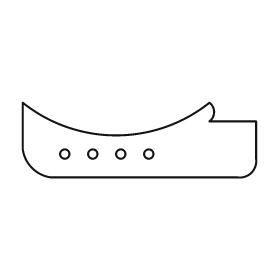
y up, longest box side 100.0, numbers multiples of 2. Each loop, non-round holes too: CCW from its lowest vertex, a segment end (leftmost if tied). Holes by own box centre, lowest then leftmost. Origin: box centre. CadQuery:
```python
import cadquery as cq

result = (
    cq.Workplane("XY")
    .moveTo(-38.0, -16.0)
    .lineTo(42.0, -16.0)
    .threePointArc((48.0, -14.0), (50.0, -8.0))
    .lineTo(50.0, 8.0)
    .lineTo(30.0, 8.0)
    .threePointArc((32.0, 12.0), (30.0, 16.0))
    .threePointArc((-10.0, 2.0), (-50.0, 16.0))
    .lineTo(-50.0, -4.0)
    .threePointArc((-46.0, -12.0), (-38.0, -16.0))
    .close()
    .moveTo(-32.0, -6.0)
    .circle(2.0)
    .moveTo(-20.0, -6.0)
    .circle(2.0)
    .moveTo(-8.0, -6.0)
    .circle(2.0)
    .moveTo(4.0, -6.0)
    .circle(2.0)
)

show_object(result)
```